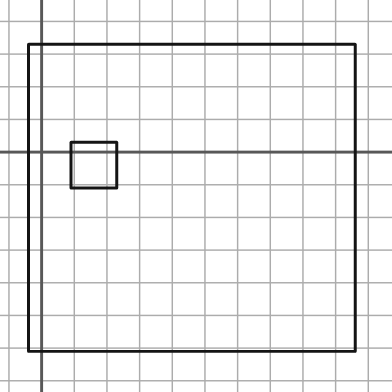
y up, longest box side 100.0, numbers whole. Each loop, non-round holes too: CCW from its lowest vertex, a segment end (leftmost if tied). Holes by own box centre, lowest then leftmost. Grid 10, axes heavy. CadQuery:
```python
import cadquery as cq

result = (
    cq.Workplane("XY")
    .moveTo(-4.0, -61.0)
    .lineTo(96.0, -61.0)
    .lineTo(96.0, 33.0)
    .lineTo(-4.0, 33.0)
    .close()
    .moveTo(9.0, -11.0)
    .lineTo(23.0, -11.0)
    .lineTo(23.0, 3.0)
    .lineTo(9.0, 3.0)
    .close()
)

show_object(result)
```